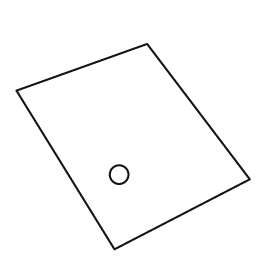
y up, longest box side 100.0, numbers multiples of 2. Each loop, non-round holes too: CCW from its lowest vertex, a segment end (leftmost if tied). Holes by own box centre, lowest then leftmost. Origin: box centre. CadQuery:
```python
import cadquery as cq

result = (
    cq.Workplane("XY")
    .moveTo(-8.0, -44.0)
    .lineTo(50.0, -14.0)
    .lineTo(6.0, 44.0)
    .lineTo(-50.0, 24.0)
    .close()
    .moveTo(-6.0, -12.0)
    .circle(4.0)
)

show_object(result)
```